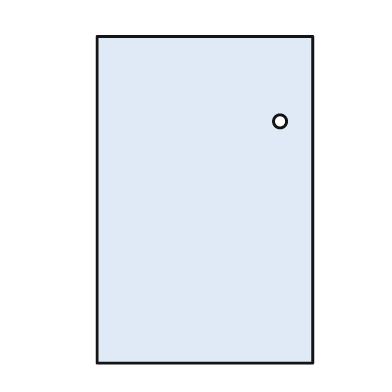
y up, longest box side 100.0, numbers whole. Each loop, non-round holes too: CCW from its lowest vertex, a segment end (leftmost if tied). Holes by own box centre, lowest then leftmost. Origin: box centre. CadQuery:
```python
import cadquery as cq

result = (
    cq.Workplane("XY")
    .moveTo(-33.0, -50.0)
    .lineTo(33.0, -50.0)
    .lineTo(33.0, 50.0)
    .lineTo(-33.0, 50.0)
    .close()
    .moveTo(23.0, 24.0)
    .circle(2.0)
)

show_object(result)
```